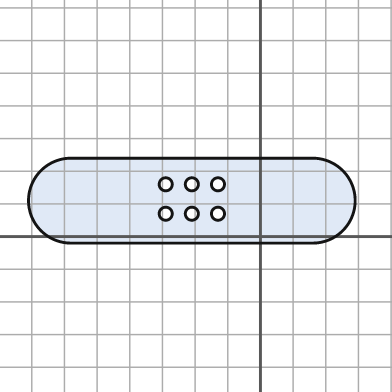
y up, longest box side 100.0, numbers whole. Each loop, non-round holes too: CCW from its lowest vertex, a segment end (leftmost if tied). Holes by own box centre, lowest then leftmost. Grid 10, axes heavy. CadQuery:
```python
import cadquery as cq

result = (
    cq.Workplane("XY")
    .moveTo(-58.0, -2.0)
    .lineTo(16.0, -2.0)
    .threePointArc((29.0, 11.0), (16.0, 24.0))
    .lineTo(-58.0, 24.0)
    .threePointArc((-71.0, 11.0), (-58.0, -2.0))
    .close()
    .moveTo(-29.0, 7.0)
    .circle(2.0)
    .moveTo(-21.0, 7.0)
    .circle(2.0)
    .moveTo(-13.0, 7.0)
    .circle(2.0)
    .moveTo(-29.0, 16.0)
    .circle(2.0)
    .moveTo(-21.0, 16.0)
    .circle(2.0)
    .moveTo(-13.0, 16.0)
    .circle(2.0)
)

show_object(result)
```